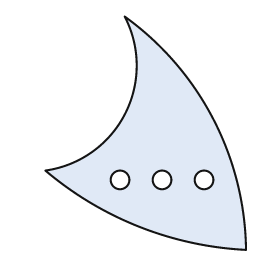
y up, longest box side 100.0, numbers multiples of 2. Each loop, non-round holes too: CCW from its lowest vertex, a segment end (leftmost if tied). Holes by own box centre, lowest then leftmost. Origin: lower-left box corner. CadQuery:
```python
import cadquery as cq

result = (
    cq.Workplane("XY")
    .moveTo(86.0, 0.0)
    .threePointArc((72.0, 56.0), (34.0, 100.0))
    .threePointArc((34.0, 58.0), (0.0, 34.0))
    .threePointArc((40.0, 10.0), (86.0, 0.0))
    .close()
    .moveTo(32.0, 30.0)
    .circle(4.0)
    .moveTo(50.0, 30.0)
    .circle(4.0)
    .moveTo(68.0, 30.0)
    .circle(4.0)
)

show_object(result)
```